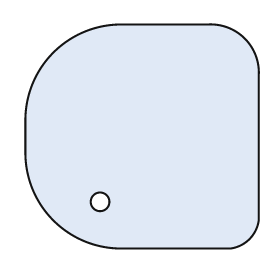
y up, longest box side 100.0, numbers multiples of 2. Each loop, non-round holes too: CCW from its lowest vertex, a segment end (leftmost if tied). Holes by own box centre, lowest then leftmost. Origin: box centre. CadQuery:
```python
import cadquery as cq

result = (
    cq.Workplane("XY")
    .moveTo(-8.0, -48.0)
    .lineTo(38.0, -48.0)
    .threePointArc((46.0, -44.0), (50.0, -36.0))
    .lineTo(50.0, 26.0)
    .threePointArc((44.0, 42.0), (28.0, 48.0))
    .lineTo(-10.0, 48.0)
    .threePointArc((-38.0, 36.0), (-50.0, 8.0))
    .lineTo(-50.0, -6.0)
    .threePointArc((-38.0, -36.0), (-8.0, -48.0))
    .close()
    .moveTo(-18.0, -28.0)
    .circle(4.0)
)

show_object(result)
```